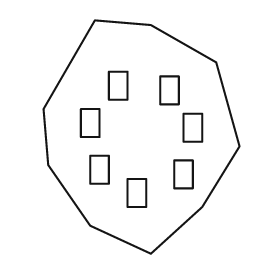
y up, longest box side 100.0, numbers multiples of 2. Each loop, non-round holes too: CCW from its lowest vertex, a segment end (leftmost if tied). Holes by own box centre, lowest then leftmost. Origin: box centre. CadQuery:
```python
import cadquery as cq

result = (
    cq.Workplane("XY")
    .moveTo(4.0, -50.0)
    .lineTo(26.0, -30.0)
    .lineTo(42.0, -4.0)
    .lineTo(32.0, 32.0)
    .lineTo(4.0, 48.0)
    .lineTo(-20.0, 50.0)
    .lineTo(-42.0, 12.0)
    .lineTo(-40.0, -12.0)
    .lineTo(-22.0, -38.0)
    .close()
    .moveTo(-6.0, -30.0)
    .lineTo(2.0, -30.0)
    .lineTo(2.0, -18.0)
    .lineTo(-6.0, -18.0)
    .close()
    .moveTo(14.0, -22.0)
    .lineTo(22.0, -22.0)
    .lineTo(22.0, -10.0)
    .lineTo(14.0, -10.0)
    .close()
    .moveTo(-22.0, -20.0)
    .lineTo(-14.0, -20.0)
    .lineTo(-14.0, -8.0)
    .lineTo(-22.0, -8.0)
    .close()
    .moveTo(18.0, -2.0)
    .lineTo(26.0, -2.0)
    .lineTo(26.0, 10.0)
    .lineTo(18.0, 10.0)
    .close()
    .moveTo(-26.0, 0.0)
    .lineTo(-18.0, 0.0)
    .lineTo(-18.0, 12.0)
    .lineTo(-26.0, 12.0)
    .close()
    .moveTo(8.0, 14.0)
    .lineTo(16.0, 14.0)
    .lineTo(16.0, 26.0)
    .lineTo(8.0, 26.0)
    .close()
    .moveTo(-14.0, 16.0)
    .lineTo(-6.0, 16.0)
    .lineTo(-6.0, 28.0)
    .lineTo(-14.0, 28.0)
    .close()
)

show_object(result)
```